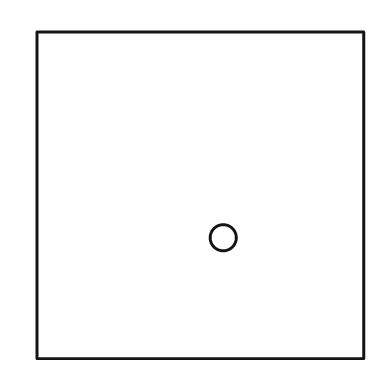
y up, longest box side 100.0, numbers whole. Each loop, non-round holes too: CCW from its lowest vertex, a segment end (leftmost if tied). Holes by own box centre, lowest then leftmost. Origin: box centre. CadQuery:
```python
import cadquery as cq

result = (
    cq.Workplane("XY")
    .moveTo(-50.0, -50.0)
    .lineTo(50.0, -50.0)
    .lineTo(50.0, 50.0)
    .lineTo(-50.0, 50.0)
    .close()
    .moveTo(7.0, -13.0)
    .circle(4.0)
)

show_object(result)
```